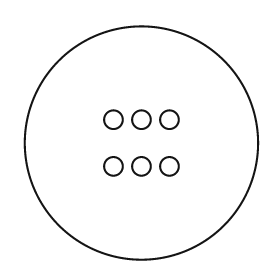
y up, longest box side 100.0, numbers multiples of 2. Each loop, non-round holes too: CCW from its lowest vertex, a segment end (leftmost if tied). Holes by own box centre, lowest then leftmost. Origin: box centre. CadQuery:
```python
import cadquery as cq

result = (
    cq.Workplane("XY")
    .moveTo(0.0, 0.0)
    .circle(50.0)
    .moveTo(-12.0, -10.0)
    .circle(4.0)
    .moveTo(0.0, -10.0)
    .circle(4.0)
    .moveTo(12.0, -10.0)
    .circle(4.0)
    .moveTo(-12.0, 10.0)
    .circle(4.0)
    .moveTo(0.0, 10.0)
    .circle(4.0)
    .moveTo(12.0, 10.0)
    .circle(4.0)
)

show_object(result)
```